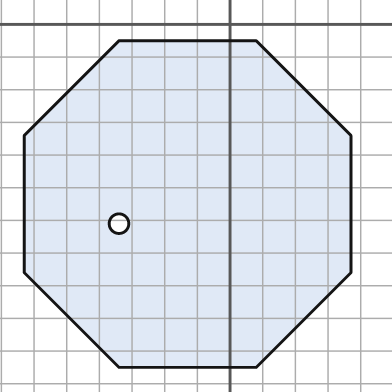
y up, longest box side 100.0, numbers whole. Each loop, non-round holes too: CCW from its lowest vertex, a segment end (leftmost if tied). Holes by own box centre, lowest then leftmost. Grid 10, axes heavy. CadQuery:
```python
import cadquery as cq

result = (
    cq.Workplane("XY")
    .moveTo(-34.0, -105.0)
    .lineTo(8.0, -105.0)
    .lineTo(37.0, -76.0)
    .lineTo(37.0, -34.0)
    .lineTo(8.0, -5.0)
    .lineTo(-34.0, -5.0)
    .lineTo(-63.0, -34.0)
    .lineTo(-63.0, -76.0)
    .close()
    .moveTo(-34.0, -61.0)
    .circle(3.0)
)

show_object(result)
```